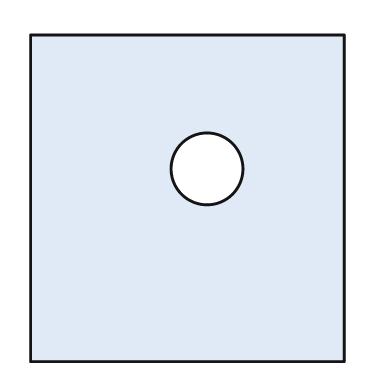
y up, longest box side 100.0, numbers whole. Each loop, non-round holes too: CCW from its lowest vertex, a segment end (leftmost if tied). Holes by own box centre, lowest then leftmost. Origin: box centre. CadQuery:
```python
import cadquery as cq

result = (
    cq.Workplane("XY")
    .moveTo(-48.0, -50.0)
    .lineTo(48.0, -50.0)
    .lineTo(48.0, 50.0)
    .lineTo(-48.0, 50.0)
    .close()
    .moveTo(6.0, 9.0)
    .circle(11.0)
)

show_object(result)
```